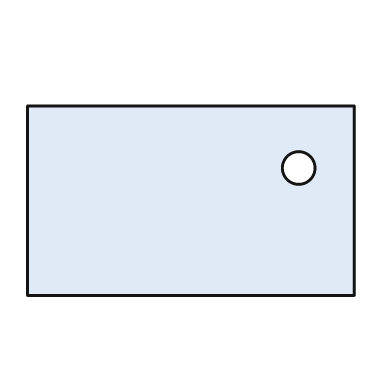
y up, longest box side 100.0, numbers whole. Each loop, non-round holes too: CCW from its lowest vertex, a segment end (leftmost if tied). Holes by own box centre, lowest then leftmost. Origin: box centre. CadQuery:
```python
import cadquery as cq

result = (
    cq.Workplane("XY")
    .moveTo(-50.0, -29.0)
    .lineTo(50.0, -29.0)
    .lineTo(50.0, 29.0)
    .lineTo(-50.0, 29.0)
    .close()
    .moveTo(33.0, 10.0)
    .circle(5.0)
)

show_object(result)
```